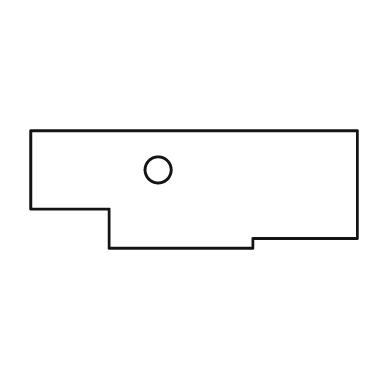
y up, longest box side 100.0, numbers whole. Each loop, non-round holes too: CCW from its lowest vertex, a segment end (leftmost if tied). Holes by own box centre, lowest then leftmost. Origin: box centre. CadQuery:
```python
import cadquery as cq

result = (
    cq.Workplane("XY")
    .moveTo(-26.0, -18.0)
    .lineTo(18.0, -18.0)
    .lineTo(18.0, -15.0)
    .lineTo(50.0, -15.0)
    .lineTo(50.0, 18.0)
    .lineTo(-50.0, 18.0)
    .lineTo(-50.0, -6.0)
    .lineTo(-26.0, -6.0)
    .close()
    .moveTo(-11.0, 6.0)
    .circle(4.0)
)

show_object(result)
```